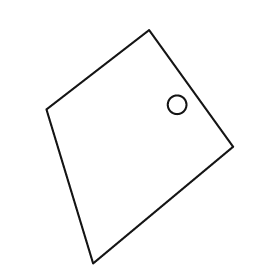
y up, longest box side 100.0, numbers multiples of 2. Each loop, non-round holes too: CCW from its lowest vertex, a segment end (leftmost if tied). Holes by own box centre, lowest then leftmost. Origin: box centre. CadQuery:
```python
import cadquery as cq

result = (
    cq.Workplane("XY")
    .moveTo(-20.0, -50.0)
    .lineTo(40.0, 0.0)
    .lineTo(4.0, 50.0)
    .lineTo(-40.0, 16.0)
    .close()
    .moveTo(16.0, 18.0)
    .circle(4.0)
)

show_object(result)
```